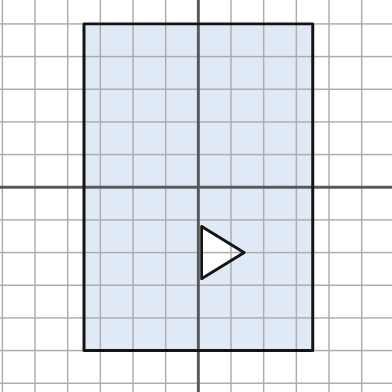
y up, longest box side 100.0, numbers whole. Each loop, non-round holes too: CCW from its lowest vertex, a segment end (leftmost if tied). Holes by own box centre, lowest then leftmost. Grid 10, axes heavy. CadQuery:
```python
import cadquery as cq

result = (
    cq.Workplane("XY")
    .moveTo(-35.0, -50.0)
    .lineTo(35.0, -50.0)
    .lineTo(35.0, 50.0)
    .lineTo(-35.0, 50.0)
    .close()
    .moveTo(1.0, -28.0)
    .lineTo(14.0, -20.0)
    .lineTo(1.0, -12.0)
    .close()
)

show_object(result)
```